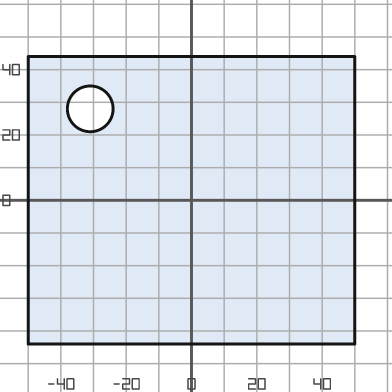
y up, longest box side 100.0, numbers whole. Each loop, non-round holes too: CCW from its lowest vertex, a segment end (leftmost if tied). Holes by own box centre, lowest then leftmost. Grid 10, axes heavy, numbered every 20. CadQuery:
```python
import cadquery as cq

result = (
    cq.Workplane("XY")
    .moveTo(-50.0, -44.0)
    .lineTo(50.0, -44.0)
    .lineTo(50.0, 44.0)
    .lineTo(-50.0, 44.0)
    .close()
    .moveTo(-31.0, 28.0)
    .circle(7.0)
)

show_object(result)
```